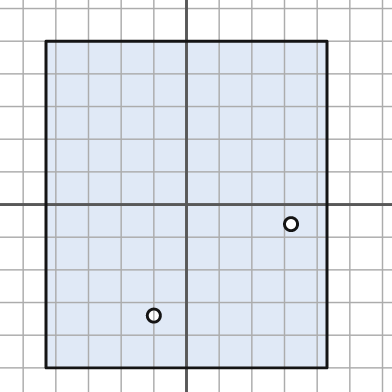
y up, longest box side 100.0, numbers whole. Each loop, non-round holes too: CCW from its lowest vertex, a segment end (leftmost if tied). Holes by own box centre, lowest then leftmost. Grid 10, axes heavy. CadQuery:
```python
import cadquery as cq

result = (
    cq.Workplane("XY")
    .moveTo(-43.0, -50.0)
    .lineTo(43.0, -50.0)
    .lineTo(43.0, 50.0)
    .lineTo(-43.0, 50.0)
    .close()
    .moveTo(-10.0, -34.0)
    .circle(2.0)
    .moveTo(32.0, -6.0)
    .circle(2.0)
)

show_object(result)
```